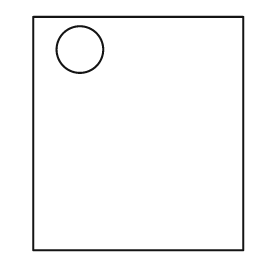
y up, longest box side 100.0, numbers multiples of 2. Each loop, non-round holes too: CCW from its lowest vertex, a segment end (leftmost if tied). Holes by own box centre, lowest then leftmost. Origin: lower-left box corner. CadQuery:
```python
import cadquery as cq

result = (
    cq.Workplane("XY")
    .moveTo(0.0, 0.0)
    .lineTo(90.0, 0.0)
    .lineTo(90.0, 100.0)
    .lineTo(0.0, 100.0)
    .close()
    .moveTo(20.0, 86.0)
    .circle(10.0)
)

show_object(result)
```